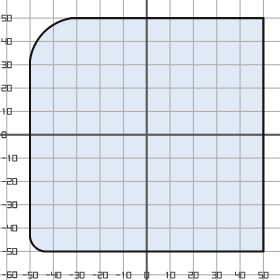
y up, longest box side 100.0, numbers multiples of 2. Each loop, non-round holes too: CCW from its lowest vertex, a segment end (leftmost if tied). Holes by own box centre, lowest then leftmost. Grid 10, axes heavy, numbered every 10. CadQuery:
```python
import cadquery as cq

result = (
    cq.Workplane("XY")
    .moveTo(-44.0, -50.0)
    .lineTo(50.0, -50.0)
    .lineTo(50.0, 50.0)
    .lineTo(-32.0, 50.0)
    .threePointArc((-44.0, 44.0), (-50.0, 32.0))
    .lineTo(-50.0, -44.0)
    .threePointArc((-48.0, -48.0), (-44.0, -50.0))
    .close()
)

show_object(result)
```